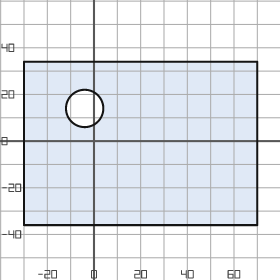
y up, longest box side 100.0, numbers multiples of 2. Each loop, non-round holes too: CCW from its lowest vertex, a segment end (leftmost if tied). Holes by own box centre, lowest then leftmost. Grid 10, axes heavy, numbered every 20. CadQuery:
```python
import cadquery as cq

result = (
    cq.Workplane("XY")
    .moveTo(-30.0, -36.0)
    .lineTo(70.0, -36.0)
    .lineTo(70.0, 34.0)
    .lineTo(-30.0, 34.0)
    .close()
    .moveTo(-4.0, 14.0)
    .circle(8.0)
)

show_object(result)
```